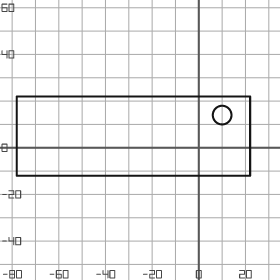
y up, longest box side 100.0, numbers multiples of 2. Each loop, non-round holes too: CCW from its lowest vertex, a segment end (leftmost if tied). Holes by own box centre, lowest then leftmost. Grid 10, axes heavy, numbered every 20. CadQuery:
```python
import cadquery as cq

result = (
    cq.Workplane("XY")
    .moveTo(-78.0, -12.0)
    .lineTo(22.0, -12.0)
    .lineTo(22.0, 22.0)
    .lineTo(-78.0, 22.0)
    .close()
    .moveTo(10.0, 14.0)
    .circle(4.0)
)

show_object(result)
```